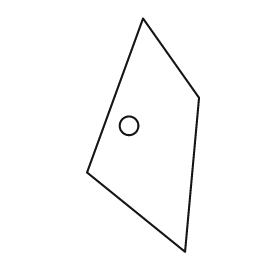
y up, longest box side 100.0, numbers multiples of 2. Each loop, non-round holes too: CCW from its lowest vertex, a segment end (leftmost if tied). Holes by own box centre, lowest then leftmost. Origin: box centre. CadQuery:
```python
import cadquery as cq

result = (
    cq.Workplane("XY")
    .moveTo(18.0, -50.0)
    .lineTo(24.0, 16.0)
    .lineTo(0.0, 50.0)
    .lineTo(-24.0, -16.0)
    .close()
    .moveTo(-6.0, 4.0)
    .circle(4.0)
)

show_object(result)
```